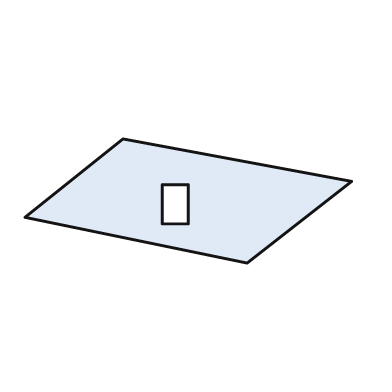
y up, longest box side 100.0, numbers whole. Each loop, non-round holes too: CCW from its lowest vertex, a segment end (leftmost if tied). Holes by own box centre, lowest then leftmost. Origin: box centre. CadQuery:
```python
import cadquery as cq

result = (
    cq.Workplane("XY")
    .moveTo(18.0, -19.0)
    .lineTo(50.0, 6.0)
    .lineTo(-20.0, 19.0)
    .lineTo(-50.0, -5.0)
    .close()
    .moveTo(-8.0, -7.0)
    .lineTo(0.0, -7.0)
    .lineTo(0.0, 5.0)
    .lineTo(-8.0, 5.0)
    .close()
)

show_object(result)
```